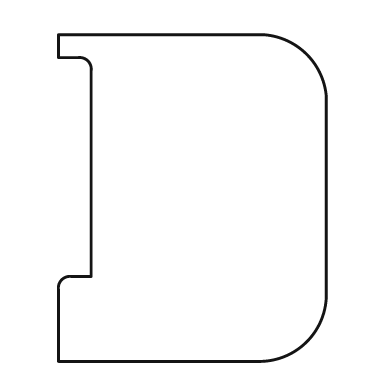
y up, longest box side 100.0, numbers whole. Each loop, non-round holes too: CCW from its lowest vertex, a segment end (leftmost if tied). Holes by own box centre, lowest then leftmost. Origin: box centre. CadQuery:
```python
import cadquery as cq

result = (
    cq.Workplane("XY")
    .moveTo(-41.0, -50.0)
    .lineTo(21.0, -50.0)
    .threePointArc((35.0, -44.0), (41.0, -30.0))
    .lineTo(41.0, 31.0)
    .threePointArc((35.0, 44.0), (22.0, 50.0))
    .lineTo(-41.0, 50.0)
    .lineTo(-41.0, 43.0)
    .lineTo(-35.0, 43.0)
    .threePointArc((-32.0, 42.0), (-31.0, 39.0))
    .lineTo(-31.0, -24.0)
    .lineTo(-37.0, -24.0)
    .threePointArc((-40.0, -25.0), (-41.0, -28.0))
    .close()
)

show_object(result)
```